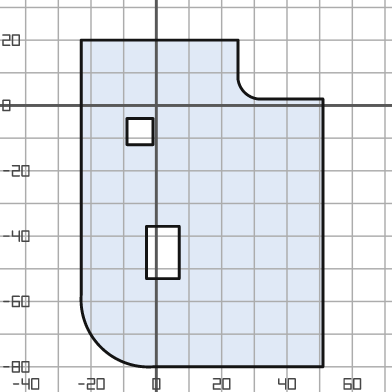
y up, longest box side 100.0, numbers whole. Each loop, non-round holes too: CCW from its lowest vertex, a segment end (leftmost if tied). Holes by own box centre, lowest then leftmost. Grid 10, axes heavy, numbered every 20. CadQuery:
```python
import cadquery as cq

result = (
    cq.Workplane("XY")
    .moveTo(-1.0, -80.0)
    .lineTo(51.0, -80.0)
    .lineTo(51.0, 2.0)
    .lineTo(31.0, 2.0)
    .threePointArc((27.0, 4.0), (25.0, 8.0))
    .lineTo(25.0, 20.0)
    .lineTo(-23.0, 20.0)
    .lineTo(-23.0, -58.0)
    .threePointArc((-17.0, -74.0), (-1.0, -80.0))
    .close()
    .moveTo(-3.0, -53.0)
    .lineTo(7.0, -53.0)
    .lineTo(7.0, -37.0)
    .lineTo(-3.0, -37.0)
    .close()
    .moveTo(-9.0, -12.0)
    .lineTo(-1.0, -12.0)
    .lineTo(-1.0, -4.0)
    .lineTo(-9.0, -4.0)
    .close()
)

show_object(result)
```